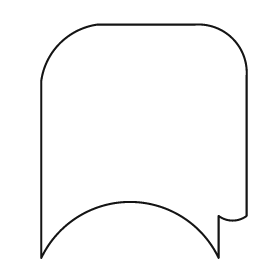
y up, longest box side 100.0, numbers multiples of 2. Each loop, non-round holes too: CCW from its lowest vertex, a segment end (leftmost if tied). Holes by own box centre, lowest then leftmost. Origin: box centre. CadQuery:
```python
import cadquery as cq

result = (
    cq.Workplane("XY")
    .moveTo(-44.0, -50.0)
    .threePointArc((-6.0, -26.0), (32.0, -50.0))
    .lineTo(32.0, -32.0)
    .threePointArc((38.0, -34.0), (44.0, -32.0))
    .lineTo(44.0, 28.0)
    .threePointArc((38.0, 44.0), (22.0, 50.0))
    .lineTo(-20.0, 50.0)
    .threePointArc((-36.0, 42.0), (-44.0, 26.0))
    .close()
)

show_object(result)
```